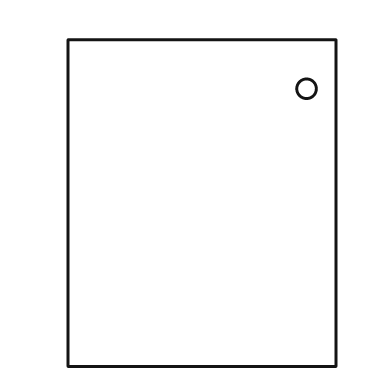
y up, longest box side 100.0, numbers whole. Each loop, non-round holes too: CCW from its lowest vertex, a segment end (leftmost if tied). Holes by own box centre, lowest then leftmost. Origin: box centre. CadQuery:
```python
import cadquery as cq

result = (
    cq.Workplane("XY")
    .moveTo(-41.0, -50.0)
    .lineTo(41.0, -50.0)
    .lineTo(41.0, 50.0)
    .lineTo(-41.0, 50.0)
    .close()
    .moveTo(32.0, 35.0)
    .circle(3.0)
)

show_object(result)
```